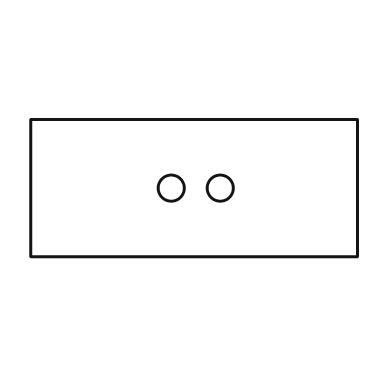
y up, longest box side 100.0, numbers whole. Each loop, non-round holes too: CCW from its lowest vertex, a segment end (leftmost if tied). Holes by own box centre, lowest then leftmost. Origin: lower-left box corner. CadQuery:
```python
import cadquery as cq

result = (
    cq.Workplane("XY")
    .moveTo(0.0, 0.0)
    .lineTo(100.0, 0.0)
    .lineTo(100.0, 42.0)
    .lineTo(0.0, 42.0)
    .close()
    .moveTo(43.0, 21.0)
    .circle(4.0)
    .moveTo(58.0, 21.0)
    .circle(4.0)
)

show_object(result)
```